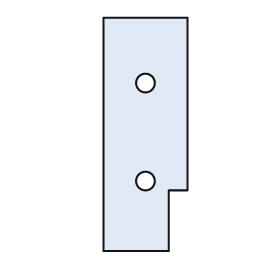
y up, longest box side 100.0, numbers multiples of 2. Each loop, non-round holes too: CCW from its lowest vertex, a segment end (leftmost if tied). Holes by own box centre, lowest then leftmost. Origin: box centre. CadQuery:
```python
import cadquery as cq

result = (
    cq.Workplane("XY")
    .moveTo(-18.0, -50.0)
    .lineTo(10.0, -50.0)
    .lineTo(10.0, -24.0)
    .lineTo(18.0, -24.0)
    .lineTo(18.0, 50.0)
    .lineTo(-18.0, 50.0)
    .close()
    .moveTo(0.0, -20.0)
    .circle(4.0)
    .moveTo(0.0, 22.0)
    .circle(4.0)
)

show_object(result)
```